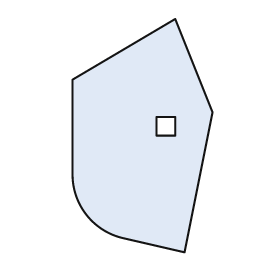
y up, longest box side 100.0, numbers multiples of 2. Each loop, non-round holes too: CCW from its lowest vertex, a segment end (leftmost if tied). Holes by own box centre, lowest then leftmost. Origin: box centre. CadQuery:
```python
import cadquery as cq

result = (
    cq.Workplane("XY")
    .moveTo(18.0, -50.0)
    .lineTo(30.0, 10.0)
    .lineTo(14.0, 50.0)
    .lineTo(-30.0, 24.0)
    .lineTo(-30.0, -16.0)
    .threePointArc((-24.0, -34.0), (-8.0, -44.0))
    .close()
    .moveTo(6.0, 0.0)
    .lineTo(14.0, 0.0)
    .lineTo(14.0, 8.0)
    .lineTo(6.0, 8.0)
    .close()
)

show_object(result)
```